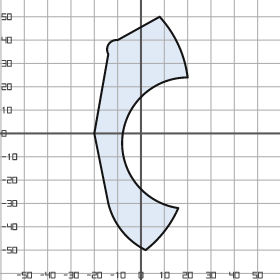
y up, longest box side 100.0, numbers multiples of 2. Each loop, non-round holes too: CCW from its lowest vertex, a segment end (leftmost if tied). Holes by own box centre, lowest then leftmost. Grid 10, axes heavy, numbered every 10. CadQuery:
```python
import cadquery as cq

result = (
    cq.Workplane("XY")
    .moveTo(2.0, -50.0)
    .threePointArc((10.0, -42.0), (16.0, -32.0))
    .threePointArc((-8.0, -2.0), (20.0, 24.0))
    .threePointArc((16.0, 38.0), (8.0, 50.0))
    .lineTo(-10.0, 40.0)
    .threePointArc((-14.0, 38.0), (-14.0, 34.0))
    .lineTo(-20.0, 0.0)
    .lineTo(-14.0, -30.0)
    .threePointArc((-8.0, -42.0), (2.0, -50.0))
    .close()
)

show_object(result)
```